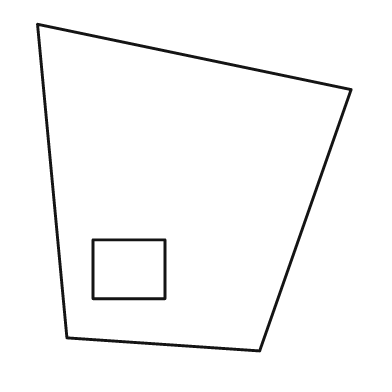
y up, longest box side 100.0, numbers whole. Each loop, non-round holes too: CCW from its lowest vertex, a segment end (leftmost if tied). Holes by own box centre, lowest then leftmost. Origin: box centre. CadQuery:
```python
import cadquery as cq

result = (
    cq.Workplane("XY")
    .moveTo(20.0, -50.0)
    .lineTo(48.0, 30.0)
    .lineTo(-48.0, 50.0)
    .lineTo(-39.0, -46.0)
    .close()
    .moveTo(-31.0, -34.0)
    .lineTo(-9.0, -34.0)
    .lineTo(-9.0, -16.0)
    .lineTo(-31.0, -16.0)
    .close()
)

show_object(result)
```